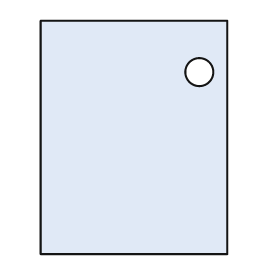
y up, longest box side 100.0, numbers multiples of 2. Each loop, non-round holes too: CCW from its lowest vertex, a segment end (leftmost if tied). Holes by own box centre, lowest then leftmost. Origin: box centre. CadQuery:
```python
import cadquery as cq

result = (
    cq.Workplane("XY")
    .moveTo(-40.0, -50.0)
    .lineTo(40.0, -50.0)
    .lineTo(40.0, 50.0)
    .lineTo(-40.0, 50.0)
    .close()
    .moveTo(28.0, 28.0)
    .circle(6.0)
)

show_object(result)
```